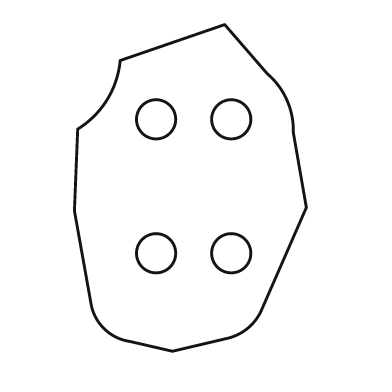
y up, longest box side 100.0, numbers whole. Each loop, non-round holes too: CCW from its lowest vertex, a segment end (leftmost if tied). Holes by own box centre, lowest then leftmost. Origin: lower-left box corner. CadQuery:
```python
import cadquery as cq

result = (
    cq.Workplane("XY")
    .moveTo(30.0, 0.0)
    .lineTo(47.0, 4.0)
    .threePointArc((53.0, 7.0), (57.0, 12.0))
    .lineTo(71.0, 44.0)
    .lineTo(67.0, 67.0)
    .threePointArc((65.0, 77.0), (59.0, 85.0))
    .lineTo(46.0, 100.0)
    .lineTo(14.0, 89.0)
    .threePointArc((10.0, 77.0), (1.0, 68.0))
    .lineTo(0.0, 43.0)
    .lineTo(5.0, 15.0)
    .threePointArc((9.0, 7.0), (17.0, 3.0))
    .close()
    .moveTo(25.0, 30.0)
    .circle(6.0)
    .moveTo(48.0, 30.0)
    .circle(6.0)
    .moveTo(25.0, 71.0)
    .circle(6.0)
    .moveTo(48.0, 71.0)
    .circle(6.0)
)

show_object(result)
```